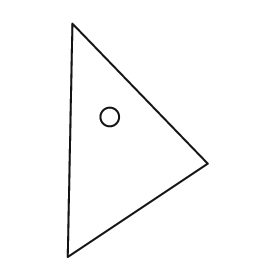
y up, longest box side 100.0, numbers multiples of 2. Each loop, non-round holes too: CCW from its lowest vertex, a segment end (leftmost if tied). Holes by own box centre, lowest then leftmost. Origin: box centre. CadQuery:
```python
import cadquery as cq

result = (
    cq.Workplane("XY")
    .moveTo(-30.0, -50.0)
    .lineTo(30.0, -10.0)
    .lineTo(-28.0, 50.0)
    .close()
    .moveTo(-12.0, 10.0)
    .circle(4.0)
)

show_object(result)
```